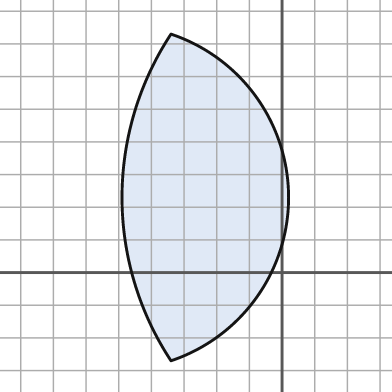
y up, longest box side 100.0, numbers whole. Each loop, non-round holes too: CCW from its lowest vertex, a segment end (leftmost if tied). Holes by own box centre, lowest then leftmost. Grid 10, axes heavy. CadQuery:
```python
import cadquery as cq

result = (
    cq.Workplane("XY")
    .moveTo(-34.0, -27.0)
    .threePointArc((2.0, 23.0), (-34.0, 73.0))
    .threePointArc((-49.0, 23.0), (-34.0, -27.0))
    .close()
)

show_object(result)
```